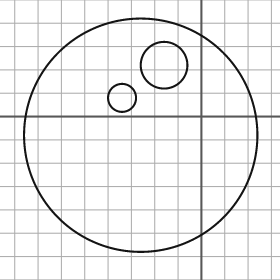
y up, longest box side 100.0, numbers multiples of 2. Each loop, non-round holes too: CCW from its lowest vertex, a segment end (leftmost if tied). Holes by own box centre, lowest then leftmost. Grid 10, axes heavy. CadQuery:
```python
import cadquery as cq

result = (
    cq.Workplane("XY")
    .moveTo(-26.0, -8.0)
    .circle(50.0)
    .moveTo(-34.0, 8.0)
    .circle(6.0)
    .moveTo(-16.0, 22.0)
    .circle(10.0)
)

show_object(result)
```